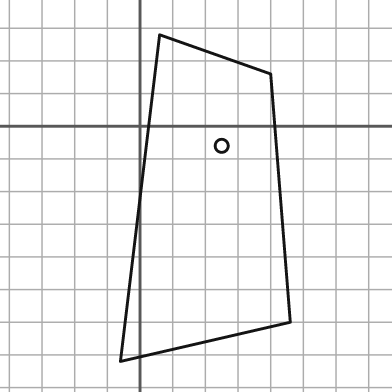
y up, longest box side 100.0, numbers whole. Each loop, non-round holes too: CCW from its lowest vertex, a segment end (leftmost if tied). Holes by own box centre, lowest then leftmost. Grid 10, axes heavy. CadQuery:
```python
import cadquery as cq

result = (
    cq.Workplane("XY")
    .moveTo(-6.0, -72.0)
    .lineTo(46.0, -60.0)
    .lineTo(40.0, 16.0)
    .lineTo(6.0, 28.0)
    .close()
    .moveTo(25.0, -6.0)
    .circle(2.0)
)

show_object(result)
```